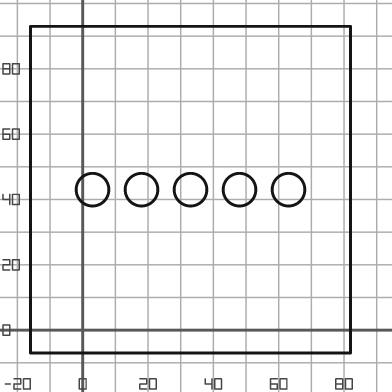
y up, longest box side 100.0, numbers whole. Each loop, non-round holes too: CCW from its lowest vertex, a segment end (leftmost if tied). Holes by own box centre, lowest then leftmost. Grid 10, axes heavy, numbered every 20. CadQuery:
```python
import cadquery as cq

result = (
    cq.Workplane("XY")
    .moveTo(-16.0, -7.0)
    .lineTo(82.0, -7.0)
    .lineTo(82.0, 93.0)
    .lineTo(-16.0, 93.0)
    .close()
    .moveTo(3.0, 43.0)
    .circle(5.0)
    .moveTo(18.0, 43.0)
    .circle(5.0)
    .moveTo(33.0, 43.0)
    .circle(5.0)
    .moveTo(48.0, 43.0)
    .circle(5.0)
    .moveTo(63.0, 43.0)
    .circle(5.0)
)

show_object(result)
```